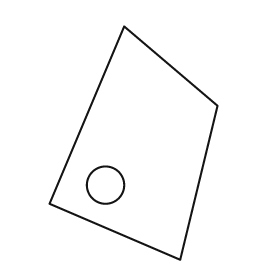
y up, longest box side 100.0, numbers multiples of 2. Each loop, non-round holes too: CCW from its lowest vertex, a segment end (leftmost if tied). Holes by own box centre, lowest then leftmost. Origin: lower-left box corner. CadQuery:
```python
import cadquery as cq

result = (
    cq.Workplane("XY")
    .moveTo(56.0, 0.0)
    .lineTo(72.0, 66.0)
    .lineTo(32.0, 100.0)
    .lineTo(0.0, 24.0)
    .close()
    .moveTo(24.0, 32.0)
    .circle(8.0)
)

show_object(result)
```